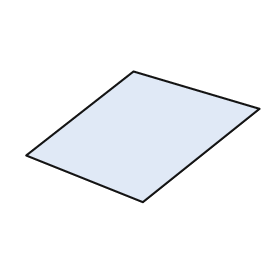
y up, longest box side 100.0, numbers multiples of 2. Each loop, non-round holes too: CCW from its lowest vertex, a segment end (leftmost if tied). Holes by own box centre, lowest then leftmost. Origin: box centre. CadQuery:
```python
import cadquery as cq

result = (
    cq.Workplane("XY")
    .moveTo(0.0, -28.0)
    .lineTo(50.0, 12.0)
    .lineTo(-4.0, 28.0)
    .lineTo(-50.0, -8.0)
    .close()
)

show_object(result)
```